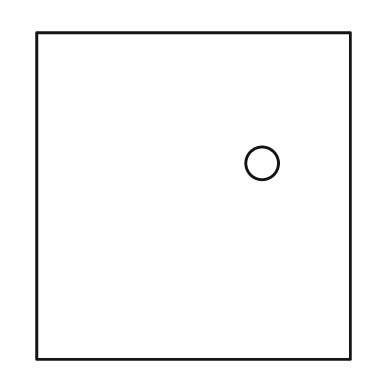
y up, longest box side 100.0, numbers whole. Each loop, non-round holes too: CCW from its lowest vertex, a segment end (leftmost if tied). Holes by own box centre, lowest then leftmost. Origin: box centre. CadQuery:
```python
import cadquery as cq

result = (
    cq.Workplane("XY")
    .moveTo(-48.0, -50.0)
    .lineTo(48.0, -50.0)
    .lineTo(48.0, 50.0)
    .lineTo(-48.0, 50.0)
    .close()
    .moveTo(21.0, 10.0)
    .circle(5.0)
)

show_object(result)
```